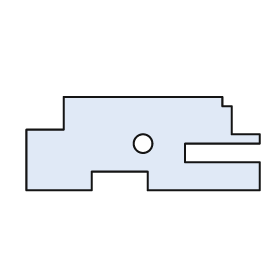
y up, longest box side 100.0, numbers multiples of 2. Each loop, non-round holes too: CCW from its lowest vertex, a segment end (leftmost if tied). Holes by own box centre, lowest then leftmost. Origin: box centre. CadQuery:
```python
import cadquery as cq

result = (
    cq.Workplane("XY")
    .moveTo(-50.0, -20.0)
    .lineTo(-22.0, -20.0)
    .lineTo(-22.0, -12.0)
    .lineTo(2.0, -12.0)
    .lineTo(2.0, -20.0)
    .lineTo(50.0, -20.0)
    .lineTo(50.0, -8.0)
    .lineTo(18.0, -8.0)
    .lineTo(18.0, 0.0)
    .lineTo(50.0, 0.0)
    .lineTo(50.0, 4.0)
    .lineTo(38.0, 4.0)
    .lineTo(38.0, 16.0)
    .lineTo(34.0, 16.0)
    .lineTo(34.0, 20.0)
    .lineTo(-34.0, 20.0)
    .lineTo(-34.0, 6.0)
    .lineTo(-50.0, 6.0)
    .close()
    .moveTo(0.0, 0.0)
    .circle(4.0)
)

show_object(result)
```